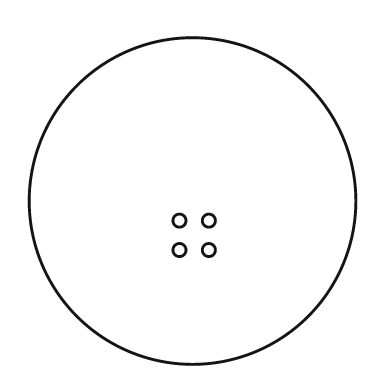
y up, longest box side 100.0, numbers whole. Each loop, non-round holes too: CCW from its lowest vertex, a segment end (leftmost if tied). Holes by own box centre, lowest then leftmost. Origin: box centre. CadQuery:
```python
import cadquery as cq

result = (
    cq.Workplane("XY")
    .moveTo(0.0, 0.0)
    .circle(50.0)
    .moveTo(-4.0, -15.0)
    .circle(2.0)
    .moveTo(5.0, -15.0)
    .circle(2.0)
    .moveTo(-4.0, -6.0)
    .circle(2.0)
    .moveTo(5.0, -6.0)
    .circle(2.0)
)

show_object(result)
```